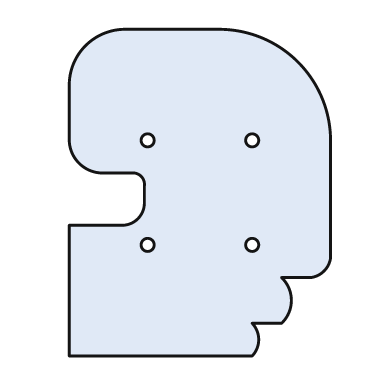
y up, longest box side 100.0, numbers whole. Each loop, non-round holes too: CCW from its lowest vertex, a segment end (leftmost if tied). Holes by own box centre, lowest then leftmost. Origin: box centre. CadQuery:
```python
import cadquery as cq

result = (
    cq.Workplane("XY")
    .moveTo(-40.0, -50.0)
    .lineTo(16.0, -50.0)
    .threePointArc((18.0, -45.0), (16.0, -40.0))
    .lineTo(25.0, -40.0)
    .threePointArc((28.0, -33.0), (25.0, -26.0))
    .lineTo(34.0, -26.0)
    .threePointArc((38.0, -24.0), (40.0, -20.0))
    .lineTo(40.0, 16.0)
    .threePointArc((30.0, 40.0), (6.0, 50.0))
    .lineTo(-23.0, 50.0)
    .threePointArc((-35.0, 45.0), (-40.0, 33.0))
    .lineTo(-40.0, 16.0)
    .threePointArc((-37.0, 9.0), (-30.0, 6.0))
    .lineTo(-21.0, 6.0)
    .threePointArc((-18.0, 5.0), (-17.0, 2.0))
    .lineTo(-17.0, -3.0)
    .threePointArc((-19.0, -8.0), (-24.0, -10.0))
    .lineTo(-40.0, -10.0)
    .close()
    .moveTo(-16.0, -16.0)
    .circle(2.0)
    .moveTo(16.0, -16.0)
    .circle(2.0)
    .moveTo(-16.0, 16.0)
    .circle(2.0)
    .moveTo(16.0, 16.0)
    .circle(2.0)
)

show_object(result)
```